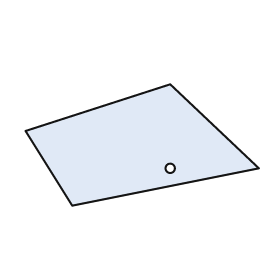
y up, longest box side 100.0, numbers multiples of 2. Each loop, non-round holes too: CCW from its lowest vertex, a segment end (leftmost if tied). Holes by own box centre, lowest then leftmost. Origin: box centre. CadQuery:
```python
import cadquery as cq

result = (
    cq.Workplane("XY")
    .moveTo(-30.0, -26.0)
    .lineTo(50.0, -10.0)
    .lineTo(12.0, 26.0)
    .lineTo(-50.0, 6.0)
    .close()
    .moveTo(12.0, -10.0)
    .circle(2.0)
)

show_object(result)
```